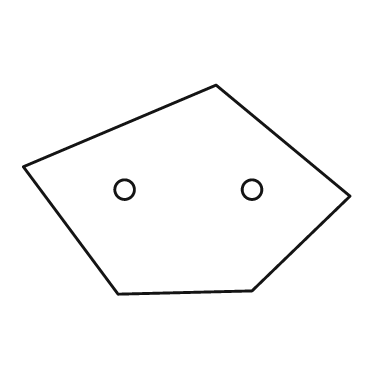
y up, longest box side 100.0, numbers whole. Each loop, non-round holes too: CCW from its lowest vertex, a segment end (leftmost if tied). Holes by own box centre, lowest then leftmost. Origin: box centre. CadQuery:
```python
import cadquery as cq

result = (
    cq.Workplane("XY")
    .moveTo(-21.0, -32.0)
    .lineTo(20.0, -31.0)
    .lineTo(50.0, -2.0)
    .lineTo(9.0, 32.0)
    .lineTo(-50.0, 7.0)
    .close()
    .moveTo(-19.0, 0.0)
    .circle(3.0)
    .moveTo(20.0, 0.0)
    .circle(3.0)
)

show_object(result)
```